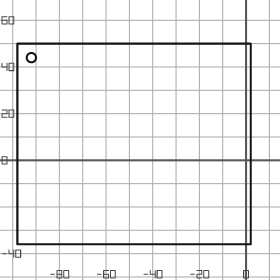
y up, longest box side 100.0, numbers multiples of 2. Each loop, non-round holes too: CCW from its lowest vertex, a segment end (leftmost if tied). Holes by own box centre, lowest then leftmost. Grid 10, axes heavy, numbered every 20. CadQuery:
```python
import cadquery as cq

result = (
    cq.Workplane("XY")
    .moveTo(-98.0, -36.0)
    .lineTo(2.0, -36.0)
    .lineTo(2.0, 50.0)
    .lineTo(-98.0, 50.0)
    .close()
    .moveTo(-92.0, 44.0)
    .circle(2.0)
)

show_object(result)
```